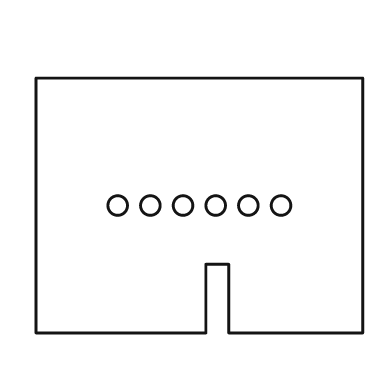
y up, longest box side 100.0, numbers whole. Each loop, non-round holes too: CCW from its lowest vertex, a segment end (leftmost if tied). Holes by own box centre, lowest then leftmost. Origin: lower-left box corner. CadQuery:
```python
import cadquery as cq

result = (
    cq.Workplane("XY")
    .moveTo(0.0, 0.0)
    .lineTo(52.0, 0.0)
    .lineTo(52.0, 21.0)
    .lineTo(59.0, 21.0)
    .lineTo(59.0, 0.0)
    .lineTo(100.0, 0.0)
    .lineTo(100.0, 78.0)
    .lineTo(0.0, 78.0)
    .close()
    .moveTo(25.0, 39.0)
    .circle(3.0)
    .moveTo(35.0, 39.0)
    .circle(3.0)
    .moveTo(45.0, 39.0)
    .circle(3.0)
    .moveTo(55.0, 39.0)
    .circle(3.0)
    .moveTo(65.0, 39.0)
    .circle(3.0)
    .moveTo(75.0, 39.0)
    .circle(3.0)
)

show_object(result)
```